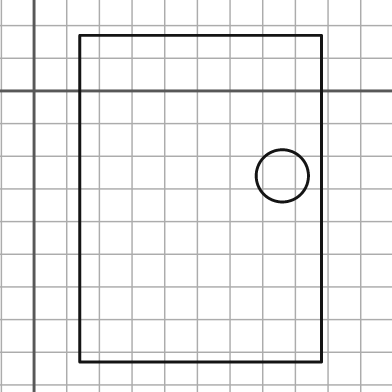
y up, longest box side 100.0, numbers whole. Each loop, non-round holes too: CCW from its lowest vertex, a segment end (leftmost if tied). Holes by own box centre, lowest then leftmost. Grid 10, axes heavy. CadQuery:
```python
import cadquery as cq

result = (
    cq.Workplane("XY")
    .moveTo(14.0, -83.0)
    .lineTo(88.0, -83.0)
    .lineTo(88.0, 17.0)
    .lineTo(14.0, 17.0)
    .close()
    .moveTo(76.0, -26.0)
    .circle(8.0)
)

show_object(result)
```